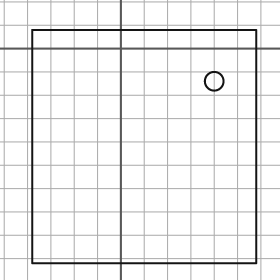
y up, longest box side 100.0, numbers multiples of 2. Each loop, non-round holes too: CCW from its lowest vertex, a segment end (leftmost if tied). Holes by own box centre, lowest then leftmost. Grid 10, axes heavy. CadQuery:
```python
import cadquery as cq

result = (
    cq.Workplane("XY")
    .moveTo(-38.0, -92.0)
    .lineTo(58.0, -92.0)
    .lineTo(58.0, 8.0)
    .lineTo(-38.0, 8.0)
    .close()
    .moveTo(40.0, -14.0)
    .circle(4.0)
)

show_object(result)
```